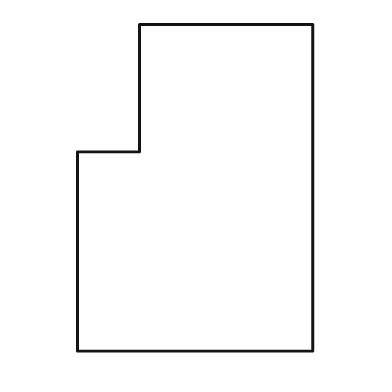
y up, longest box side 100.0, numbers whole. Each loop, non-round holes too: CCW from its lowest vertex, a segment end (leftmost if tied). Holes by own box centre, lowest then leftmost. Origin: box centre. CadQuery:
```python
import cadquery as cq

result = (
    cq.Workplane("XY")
    .moveTo(-36.0, -50.0)
    .lineTo(36.0, -50.0)
    .lineTo(36.0, 50.0)
    .lineTo(-17.0, 50.0)
    .lineTo(-17.0, 11.0)
    .lineTo(-36.0, 11.0)
    .close()
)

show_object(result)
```